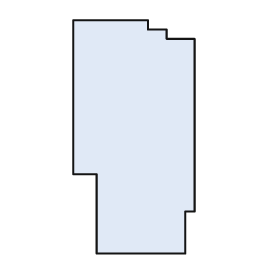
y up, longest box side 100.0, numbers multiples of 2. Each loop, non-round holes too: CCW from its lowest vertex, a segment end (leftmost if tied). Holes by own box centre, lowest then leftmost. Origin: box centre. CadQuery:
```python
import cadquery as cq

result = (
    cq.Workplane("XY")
    .moveTo(-16.0, -50.0)
    .lineTo(22.0, -50.0)
    .lineTo(22.0, -32.0)
    .lineTo(26.0, -32.0)
    .lineTo(26.0, 42.0)
    .lineTo(14.0, 42.0)
    .lineTo(14.0, 46.0)
    .lineTo(6.0, 46.0)
    .lineTo(6.0, 50.0)
    .lineTo(-26.0, 50.0)
    .lineTo(-26.0, -16.0)
    .lineTo(-16.0, -16.0)
    .close()
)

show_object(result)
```